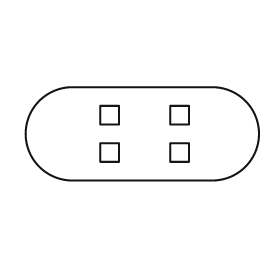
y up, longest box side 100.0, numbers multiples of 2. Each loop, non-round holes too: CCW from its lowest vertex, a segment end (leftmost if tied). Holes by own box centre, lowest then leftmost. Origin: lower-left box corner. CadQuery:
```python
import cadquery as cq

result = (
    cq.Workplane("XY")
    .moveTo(20.0, 0.0)
    .lineTo(80.0, 0.0)
    .threePointArc((100.0, 20.0), (80.0, 40.0))
    .lineTo(20.0, 40.0)
    .threePointArc((0.0, 20.0), (20.0, 0.0))
    .close()
    .moveTo(32.0, 8.0)
    .lineTo(40.0, 8.0)
    .lineTo(40.0, 16.0)
    .lineTo(32.0, 16.0)
    .close()
    .moveTo(62.0, 8.0)
    .lineTo(70.0, 8.0)
    .lineTo(70.0, 16.0)
    .lineTo(62.0, 16.0)
    .close()
    .moveTo(32.0, 24.0)
    .lineTo(40.0, 24.0)
    .lineTo(40.0, 32.0)
    .lineTo(32.0, 32.0)
    .close()
    .moveTo(62.0, 24.0)
    .lineTo(70.0, 24.0)
    .lineTo(70.0, 32.0)
    .lineTo(62.0, 32.0)
    .close()
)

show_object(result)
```